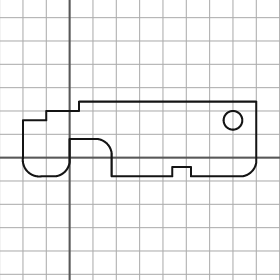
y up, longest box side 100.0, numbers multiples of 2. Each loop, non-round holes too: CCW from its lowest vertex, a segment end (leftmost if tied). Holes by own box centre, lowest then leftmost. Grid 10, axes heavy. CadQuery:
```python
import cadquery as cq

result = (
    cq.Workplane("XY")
    .moveTo(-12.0, -8.0)
    .lineTo(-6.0, -8.0)
    .threePointArc((-2.0, -6.0), (0.0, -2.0))
    .lineTo(0.0, 8.0)
    .lineTo(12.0, 8.0)
    .threePointArc((16.0, 6.0), (18.0, 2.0))
    .lineTo(18.0, -8.0)
    .lineTo(44.0, -8.0)
    .lineTo(44.0, -4.0)
    .lineTo(52.0, -4.0)
    .lineTo(52.0, -8.0)
    .lineTo(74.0, -8.0)
    .threePointArc((78.0, -6.0), (80.0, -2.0))
    .lineTo(80.0, 24.0)
    .lineTo(4.0, 24.0)
    .lineTo(4.0, 20.0)
    .lineTo(-10.0, 20.0)
    .lineTo(-10.0, 16.0)
    .lineTo(-20.0, 16.0)
    .lineTo(-20.0, 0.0)
    .threePointArc((-18.0, -6.0), (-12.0, -8.0))
    .close()
    .moveTo(70.0, 16.0)
    .circle(4.0)
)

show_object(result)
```